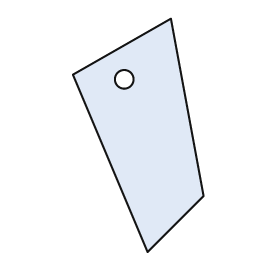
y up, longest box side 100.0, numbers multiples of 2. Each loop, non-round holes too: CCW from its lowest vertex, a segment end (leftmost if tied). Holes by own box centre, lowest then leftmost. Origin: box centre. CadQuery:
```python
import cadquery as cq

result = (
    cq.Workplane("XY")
    .moveTo(4.0, -50.0)
    .lineTo(28.0, -26.0)
    .lineTo(14.0, 50.0)
    .lineTo(-28.0, 26.0)
    .close()
    .moveTo(-6.0, 24.0)
    .circle(4.0)
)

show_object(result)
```